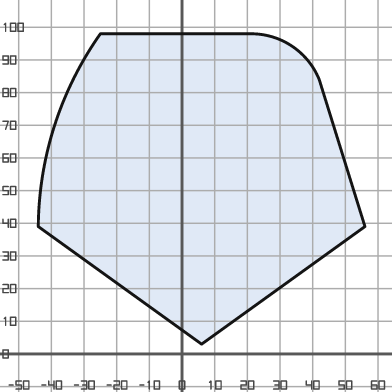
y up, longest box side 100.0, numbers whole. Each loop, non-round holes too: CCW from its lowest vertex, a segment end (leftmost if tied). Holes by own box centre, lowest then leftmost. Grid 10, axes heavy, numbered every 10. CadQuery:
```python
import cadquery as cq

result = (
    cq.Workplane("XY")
    .moveTo(6.0, 3.0)
    .lineTo(56.0, 39.0)
    .lineTo(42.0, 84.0)
    .threePointArc((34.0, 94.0), (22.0, 98.0))
    .lineTo(-25.0, 98.0)
    .threePointArc((-39.0, 70.0), (-44.0, 39.0))
    .close()
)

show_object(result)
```